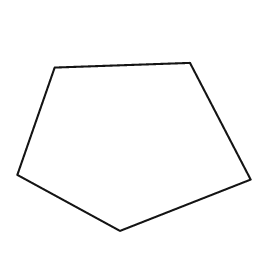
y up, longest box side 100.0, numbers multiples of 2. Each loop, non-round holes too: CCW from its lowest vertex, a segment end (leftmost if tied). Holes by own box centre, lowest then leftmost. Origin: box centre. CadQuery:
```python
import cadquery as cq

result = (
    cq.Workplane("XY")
    .moveTo(-6.0, -36.0)
    .lineTo(50.0, -14.0)
    .lineTo(24.0, 36.0)
    .lineTo(-34.0, 34.0)
    .lineTo(-50.0, -12.0)
    .close()
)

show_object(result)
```